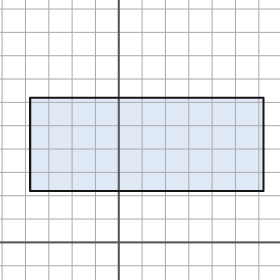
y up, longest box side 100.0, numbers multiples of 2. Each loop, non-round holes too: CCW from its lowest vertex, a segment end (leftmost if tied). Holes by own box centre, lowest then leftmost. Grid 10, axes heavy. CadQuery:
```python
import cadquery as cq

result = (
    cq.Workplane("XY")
    .moveTo(-38.0, 22.0)
    .lineTo(62.0, 22.0)
    .lineTo(62.0, 62.0)
    .lineTo(-38.0, 62.0)
    .close()
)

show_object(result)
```